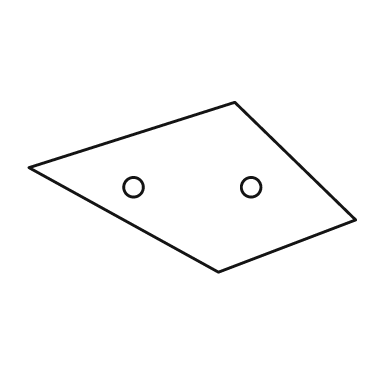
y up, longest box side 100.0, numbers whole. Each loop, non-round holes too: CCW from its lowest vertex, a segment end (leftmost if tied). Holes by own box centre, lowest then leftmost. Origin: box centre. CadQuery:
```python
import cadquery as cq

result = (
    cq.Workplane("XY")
    .moveTo(8.0, -26.0)
    .lineTo(50.0, -10.0)
    .lineTo(13.0, 26.0)
    .lineTo(-50.0, 6.0)
    .close()
    .moveTo(-18.0, 0.0)
    .circle(3.0)
    .moveTo(18.0, 0.0)
    .circle(3.0)
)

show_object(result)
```